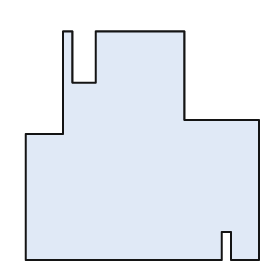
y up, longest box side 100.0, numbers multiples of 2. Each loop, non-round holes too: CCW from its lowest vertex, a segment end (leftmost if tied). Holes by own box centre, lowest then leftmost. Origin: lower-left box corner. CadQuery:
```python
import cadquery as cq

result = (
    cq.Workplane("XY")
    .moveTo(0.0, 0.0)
    .lineTo(84.0, 0.0)
    .lineTo(84.0, 12.0)
    .lineTo(88.0, 12.0)
    .lineTo(88.0, 0.0)
    .lineTo(100.0, 0.0)
    .lineTo(100.0, 60.0)
    .lineTo(68.0, 60.0)
    .lineTo(68.0, 98.0)
    .lineTo(30.0, 98.0)
    .lineTo(30.0, 76.0)
    .lineTo(20.0, 76.0)
    .lineTo(20.0, 98.0)
    .lineTo(16.0, 98.0)
    .lineTo(16.0, 54.0)
    .lineTo(0.0, 54.0)
    .close()
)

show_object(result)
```